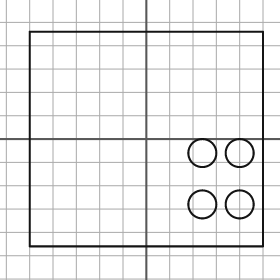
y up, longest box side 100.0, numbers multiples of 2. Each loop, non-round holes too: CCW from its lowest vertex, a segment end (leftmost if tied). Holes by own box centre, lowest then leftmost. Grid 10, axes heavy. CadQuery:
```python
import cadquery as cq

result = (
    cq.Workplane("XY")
    .moveTo(-50.0, -46.0)
    .lineTo(50.0, -46.0)
    .lineTo(50.0, 46.0)
    .lineTo(-50.0, 46.0)
    .close()
    .moveTo(24.0, -28.0)
    .circle(6.0)
    .moveTo(40.0, -28.0)
    .circle(6.0)
    .moveTo(24.0, -6.0)
    .circle(6.0)
    .moveTo(40.0, -6.0)
    .circle(6.0)
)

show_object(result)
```